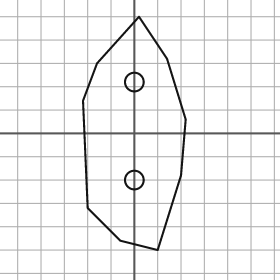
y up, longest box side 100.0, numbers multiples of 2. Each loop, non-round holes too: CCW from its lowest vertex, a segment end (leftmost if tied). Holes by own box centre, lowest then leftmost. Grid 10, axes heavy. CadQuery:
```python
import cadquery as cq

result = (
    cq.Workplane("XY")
    .moveTo(10.0, -50.0)
    .lineTo(20.0, -18.0)
    .lineTo(22.0, 6.0)
    .lineTo(14.0, 32.0)
    .lineTo(2.0, 50.0)
    .lineTo(-16.0, 30.0)
    .lineTo(-22.0, 14.0)
    .lineTo(-20.0, -32.0)
    .lineTo(-6.0, -46.0)
    .close()
    .moveTo(0.0, -20.0)
    .circle(4.0)
    .moveTo(0.0, 22.0)
    .circle(4.0)
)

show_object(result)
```